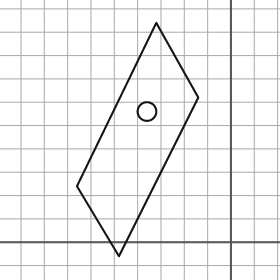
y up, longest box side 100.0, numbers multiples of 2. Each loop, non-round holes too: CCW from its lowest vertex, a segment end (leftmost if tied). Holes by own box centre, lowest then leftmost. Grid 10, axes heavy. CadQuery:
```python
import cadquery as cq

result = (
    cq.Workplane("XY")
    .moveTo(-48.0, -6.0)
    .lineTo(-14.0, 62.0)
    .lineTo(-32.0, 94.0)
    .lineTo(-66.0, 24.0)
    .close()
    .moveTo(-36.0, 56.0)
    .circle(4.0)
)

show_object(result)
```